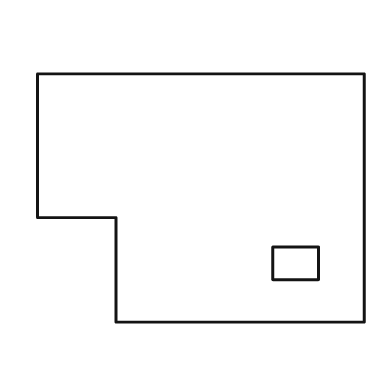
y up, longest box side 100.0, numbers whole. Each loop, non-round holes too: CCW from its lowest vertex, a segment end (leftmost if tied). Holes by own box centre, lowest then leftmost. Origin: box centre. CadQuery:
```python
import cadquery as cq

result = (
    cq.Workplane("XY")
    .moveTo(-26.0, -38.0)
    .lineTo(50.0, -38.0)
    .lineTo(50.0, 38.0)
    .lineTo(-50.0, 38.0)
    .lineTo(-50.0, -6.0)
    .lineTo(-26.0, -6.0)
    .close()
    .moveTo(22.0, -25.0)
    .lineTo(36.0, -25.0)
    .lineTo(36.0, -15.0)
    .lineTo(22.0, -15.0)
    .close()
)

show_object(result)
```